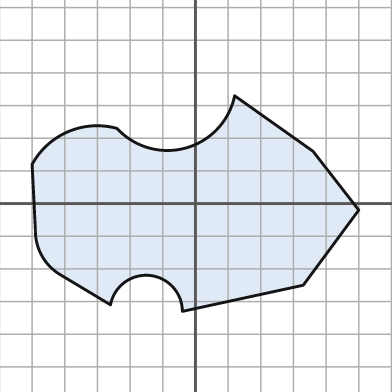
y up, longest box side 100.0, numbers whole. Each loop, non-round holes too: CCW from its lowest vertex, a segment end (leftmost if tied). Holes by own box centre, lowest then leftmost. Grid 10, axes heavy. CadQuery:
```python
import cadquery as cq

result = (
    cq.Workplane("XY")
    .moveTo(-4.0, -33.0)
    .lineTo(33.0, -25.0)
    .lineTo(50.0, -2.0)
    .lineTo(36.0, 16.0)
    .lineTo(12.0, 33.0)
    .threePointArc((-3.0, 17.0), (-24.0, 23.0))
    .threePointArc((-39.0, 22.0), (-50.0, 12.0))
    .lineTo(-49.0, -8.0)
    .threePointArc((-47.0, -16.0), (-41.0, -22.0))
    .lineTo(-26.0, -31.0)
    .threePointArc((-14.0, -22.0), (-4.0, -33.0))
    .close()
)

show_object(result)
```